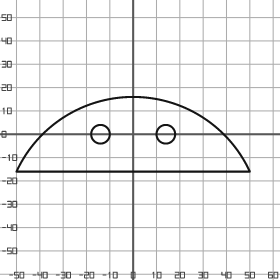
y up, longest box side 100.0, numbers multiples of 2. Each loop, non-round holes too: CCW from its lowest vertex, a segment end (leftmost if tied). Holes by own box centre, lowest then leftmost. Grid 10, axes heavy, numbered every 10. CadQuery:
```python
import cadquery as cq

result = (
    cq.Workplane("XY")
    .moveTo(-50.0, -16.0)
    .lineTo(50.0, -16.0)
    .threePointArc((0.0, 16.0), (-50.0, -16.0))
    .close()
    .moveTo(-14.0, 0.0)
    .circle(4.0)
    .moveTo(14.0, 0.0)
    .circle(4.0)
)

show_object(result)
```